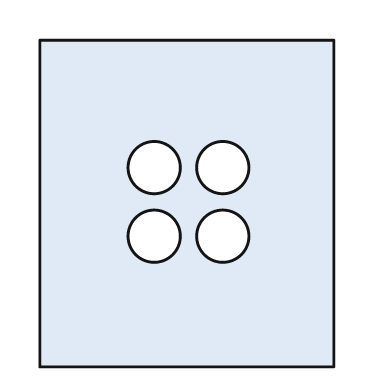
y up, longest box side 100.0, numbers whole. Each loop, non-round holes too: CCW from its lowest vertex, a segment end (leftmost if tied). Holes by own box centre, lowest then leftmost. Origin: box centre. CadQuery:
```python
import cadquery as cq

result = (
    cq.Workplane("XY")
    .moveTo(-45.0, -50.0)
    .lineTo(45.0, -50.0)
    .lineTo(45.0, 50.0)
    .lineTo(-45.0, 50.0)
    .close()
    .moveTo(-10.0, -10.0)
    .circle(8.0)
    .moveTo(11.0, -10.0)
    .circle(8.0)
    .moveTo(-10.0, 11.0)
    .circle(8.0)
    .moveTo(11.0, 11.0)
    .circle(8.0)
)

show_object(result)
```